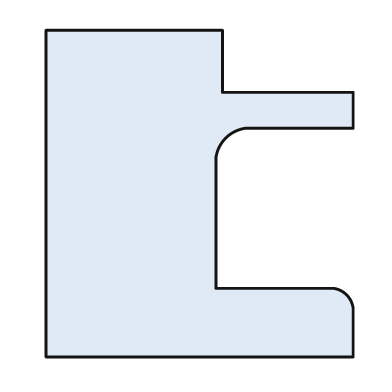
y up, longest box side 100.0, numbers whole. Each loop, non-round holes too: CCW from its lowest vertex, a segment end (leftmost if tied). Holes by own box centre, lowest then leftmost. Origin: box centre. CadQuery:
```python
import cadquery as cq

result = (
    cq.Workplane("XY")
    .moveTo(-47.0, -50.0)
    .lineTo(47.0, -50.0)
    .lineTo(47.0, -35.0)
    .threePointArc((45.0, -31.0), (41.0, -29.0))
    .lineTo(5.0, -29.0)
    .lineTo(5.0, 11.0)
    .threePointArc((8.0, 17.0), (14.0, 20.0))
    .lineTo(47.0, 20.0)
    .lineTo(47.0, 31.0)
    .lineTo(7.0, 31.0)
    .lineTo(7.0, 50.0)
    .lineTo(-47.0, 50.0)
    .close()
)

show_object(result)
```